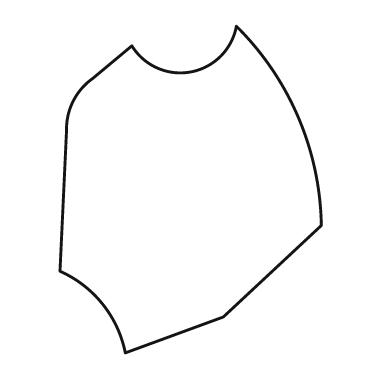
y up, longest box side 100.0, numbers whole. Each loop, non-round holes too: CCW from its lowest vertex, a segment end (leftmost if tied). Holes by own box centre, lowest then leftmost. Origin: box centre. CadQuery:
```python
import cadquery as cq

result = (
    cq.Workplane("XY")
    .moveTo(-20.0, -50.0)
    .lineTo(10.0, -39.0)
    .lineTo(40.0, -11.0)
    .threePointArc((33.0, 22.0), (14.0, 50.0))
    .threePointArc((0.0, 36.0), (-18.0, 44.0))
    .lineTo(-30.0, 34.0)
    .threePointArc((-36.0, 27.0), (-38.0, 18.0))
    .lineTo(-40.0, -25.0)
    .threePointArc((-27.0, -35.0), (-20.0, -50.0))
    .close()
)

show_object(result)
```